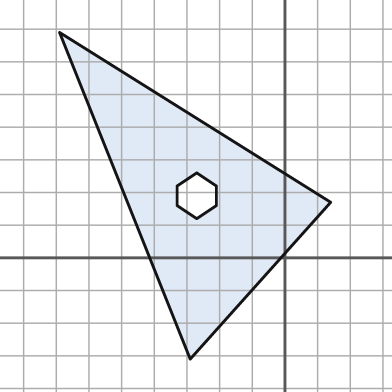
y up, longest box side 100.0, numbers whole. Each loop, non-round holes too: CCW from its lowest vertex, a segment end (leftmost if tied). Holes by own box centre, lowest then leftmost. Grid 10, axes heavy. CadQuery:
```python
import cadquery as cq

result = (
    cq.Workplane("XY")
    .moveTo(-29.0, -31.0)
    .lineTo(14.0, 17.0)
    .lineTo(-69.0, 69.0)
    .close()
    .moveTo(-27.0, 12.0)
    .lineTo(-21.0, 16.0)
    .lineTo(-21.0, 22.0)
    .lineTo(-27.0, 26.0)
    .lineTo(-33.0, 22.0)
    .lineTo(-33.0, 16.0)
    .close()
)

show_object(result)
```